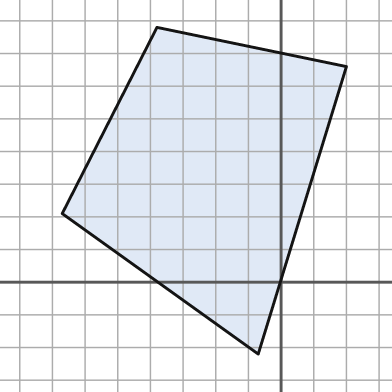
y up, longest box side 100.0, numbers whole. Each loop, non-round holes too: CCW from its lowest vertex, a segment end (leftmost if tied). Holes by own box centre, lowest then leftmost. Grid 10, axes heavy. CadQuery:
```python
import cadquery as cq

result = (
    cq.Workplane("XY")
    .moveTo(-7.0, -22.0)
    .lineTo(20.0, 66.0)
    .lineTo(-38.0, 78.0)
    .lineTo(-67.0, 21.0)
    .close()
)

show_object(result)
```